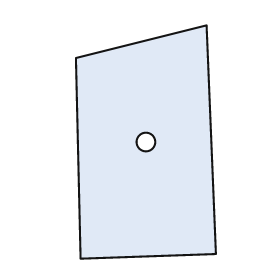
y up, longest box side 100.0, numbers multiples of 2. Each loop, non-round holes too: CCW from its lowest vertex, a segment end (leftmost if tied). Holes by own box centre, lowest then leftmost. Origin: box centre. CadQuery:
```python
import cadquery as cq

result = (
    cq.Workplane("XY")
    .moveTo(-28.0, -50.0)
    .lineTo(30.0, -48.0)
    .lineTo(26.0, 50.0)
    .lineTo(-30.0, 36.0)
    .close()
    .moveTo(0.0, 0.0)
    .circle(4.0)
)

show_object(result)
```